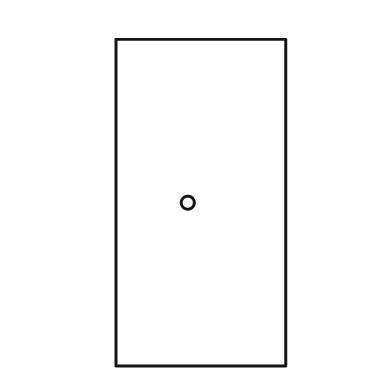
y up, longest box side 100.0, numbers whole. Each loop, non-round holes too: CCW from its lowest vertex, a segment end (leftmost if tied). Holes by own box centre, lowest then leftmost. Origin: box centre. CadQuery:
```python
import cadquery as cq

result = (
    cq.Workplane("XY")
    .moveTo(-26.0, -50.0)
    .lineTo(26.0, -50.0)
    .lineTo(26.0, 50.0)
    .lineTo(-26.0, 50.0)
    .close()
    .moveTo(-4.0, 0.0)
    .circle(2.0)
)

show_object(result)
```